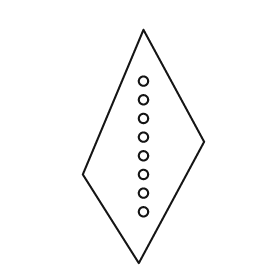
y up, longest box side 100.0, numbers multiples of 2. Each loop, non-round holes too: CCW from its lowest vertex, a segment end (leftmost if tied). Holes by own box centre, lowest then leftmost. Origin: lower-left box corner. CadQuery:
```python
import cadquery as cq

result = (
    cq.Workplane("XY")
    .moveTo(24.0, 0.0)
    .lineTo(52.0, 52.0)
    .lineTo(26.0, 100.0)
    .lineTo(0.0, 38.0)
    .close()
    .moveTo(26.0, 22.0)
    .circle(2.0)
    .moveTo(26.0, 30.0)
    .circle(2.0)
    .moveTo(26.0, 38.0)
    .circle(2.0)
    .moveTo(26.0, 46.0)
    .circle(2.0)
    .moveTo(26.0, 54.0)
    .circle(2.0)
    .moveTo(26.0, 62.0)
    .circle(2.0)
    .moveTo(26.0, 70.0)
    .circle(2.0)
    .moveTo(26.0, 78.0)
    .circle(2.0)
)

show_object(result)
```